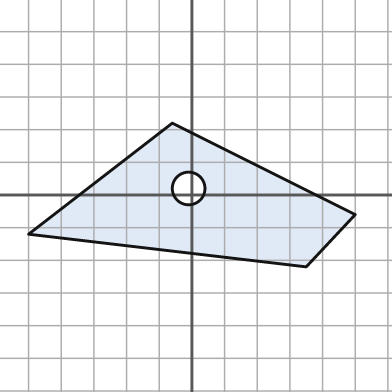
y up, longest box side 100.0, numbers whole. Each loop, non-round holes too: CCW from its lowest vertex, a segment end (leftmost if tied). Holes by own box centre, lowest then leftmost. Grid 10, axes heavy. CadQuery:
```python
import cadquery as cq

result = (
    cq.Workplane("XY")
    .moveTo(35.0, -22.0)
    .lineTo(50.0, -6.0)
    .lineTo(-6.0, 22.0)
    .lineTo(-50.0, -12.0)
    .close()
    .moveTo(-1.0, 2.0)
    .circle(5.0)
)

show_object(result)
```